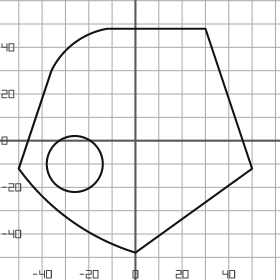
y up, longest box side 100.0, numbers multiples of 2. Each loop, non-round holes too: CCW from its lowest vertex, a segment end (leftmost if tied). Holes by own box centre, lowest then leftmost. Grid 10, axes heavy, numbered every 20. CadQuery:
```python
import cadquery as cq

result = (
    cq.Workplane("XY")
    .moveTo(0.0, -48.0)
    .lineTo(50.0, -12.0)
    .lineTo(30.0, 48.0)
    .lineTo(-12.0, 48.0)
    .threePointArc((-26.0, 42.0), (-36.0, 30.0))
    .lineTo(-50.0, -12.0)
    .threePointArc((-28.0, -34.0), (0.0, -48.0))
    .close()
    .moveTo(-26.0, -10.0)
    .circle(12.0)
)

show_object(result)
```